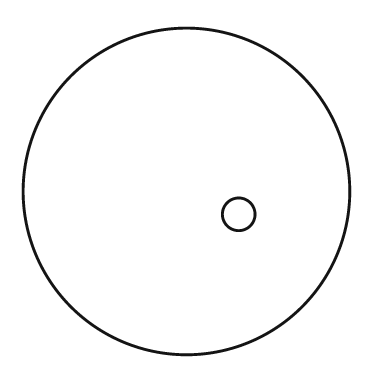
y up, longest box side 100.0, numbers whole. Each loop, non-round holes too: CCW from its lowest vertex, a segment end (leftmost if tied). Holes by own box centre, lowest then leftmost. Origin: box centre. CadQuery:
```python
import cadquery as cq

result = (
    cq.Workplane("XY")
    .moveTo(0.0, 0.0)
    .circle(50.0)
    .moveTo(16.0, -7.0)
    .circle(5.0)
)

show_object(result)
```